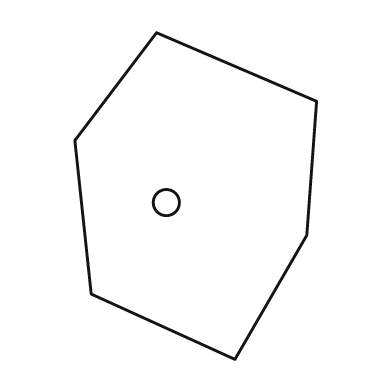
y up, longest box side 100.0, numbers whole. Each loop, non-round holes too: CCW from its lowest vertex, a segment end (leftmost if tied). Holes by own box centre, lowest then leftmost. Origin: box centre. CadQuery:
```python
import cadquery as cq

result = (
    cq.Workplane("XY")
    .moveTo(12.0, -50.0)
    .lineTo(34.0, -12.0)
    .lineTo(37.0, 29.0)
    .lineTo(-12.0, 50.0)
    .lineTo(-37.0, 17.0)
    .lineTo(-32.0, -30.0)
    .close()
    .moveTo(-9.0, -2.0)
    .circle(4.0)
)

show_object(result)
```